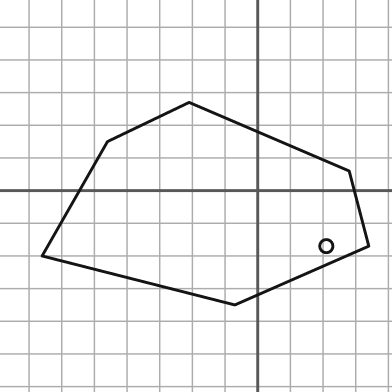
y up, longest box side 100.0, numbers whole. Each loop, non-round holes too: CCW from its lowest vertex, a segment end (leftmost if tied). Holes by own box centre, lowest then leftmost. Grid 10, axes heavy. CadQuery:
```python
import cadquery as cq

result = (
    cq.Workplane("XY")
    .moveTo(-7.0, -35.0)
    .lineTo(34.0, -17.0)
    .lineTo(28.0, 6.0)
    .lineTo(-21.0, 27.0)
    .lineTo(-46.0, 15.0)
    .lineTo(-66.0, -20.0)
    .close()
    .moveTo(21.0, -17.0)
    .circle(2.0)
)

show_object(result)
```